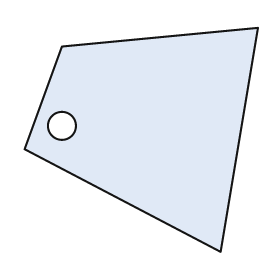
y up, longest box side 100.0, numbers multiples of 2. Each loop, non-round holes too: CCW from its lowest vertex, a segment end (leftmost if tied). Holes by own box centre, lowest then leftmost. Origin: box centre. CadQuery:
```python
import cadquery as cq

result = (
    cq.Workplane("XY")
    .moveTo(34.0, -48.0)
    .lineTo(50.0, 48.0)
    .lineTo(-34.0, 40.0)
    .lineTo(-50.0, -4.0)
    .close()
    .moveTo(-34.0, 6.0)
    .circle(6.0)
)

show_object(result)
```